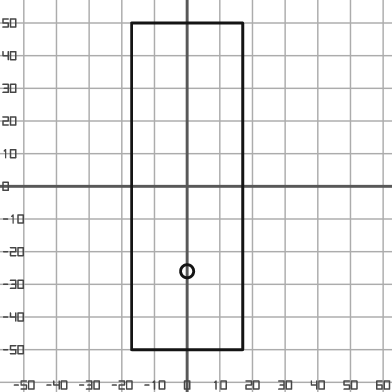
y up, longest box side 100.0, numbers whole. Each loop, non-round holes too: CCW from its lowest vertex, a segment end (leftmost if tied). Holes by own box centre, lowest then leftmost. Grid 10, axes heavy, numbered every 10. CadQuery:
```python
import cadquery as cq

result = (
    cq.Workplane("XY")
    .moveTo(-17.0, -50.0)
    .lineTo(17.0, -50.0)
    .lineTo(17.0, 50.0)
    .lineTo(-17.0, 50.0)
    .close()
    .moveTo(0.0, -26.0)
    .circle(2.0)
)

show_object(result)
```